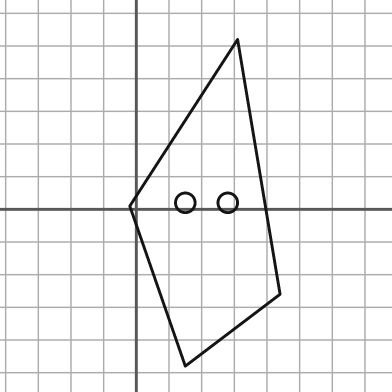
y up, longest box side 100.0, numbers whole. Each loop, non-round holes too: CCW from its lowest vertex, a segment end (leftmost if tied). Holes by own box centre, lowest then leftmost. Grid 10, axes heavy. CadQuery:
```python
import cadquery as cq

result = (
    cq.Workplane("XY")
    .moveTo(15.0, -48.0)
    .lineTo(44.0, -26.0)
    .lineTo(31.0, 52.0)
    .lineTo(-2.0, 1.0)
    .close()
    .moveTo(15.0, 2.0)
    .circle(3.0)
    .moveTo(28.0, 2.0)
    .circle(3.0)
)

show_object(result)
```